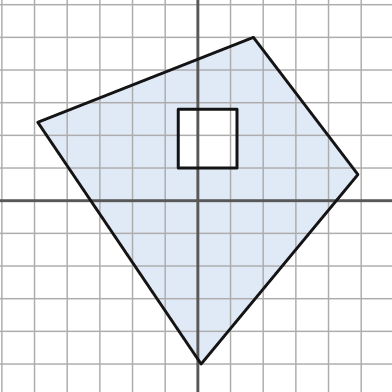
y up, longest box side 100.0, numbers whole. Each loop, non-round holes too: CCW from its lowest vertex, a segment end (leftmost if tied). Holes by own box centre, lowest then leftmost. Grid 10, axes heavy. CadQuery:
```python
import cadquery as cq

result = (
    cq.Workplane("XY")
    .moveTo(1.0, -50.0)
    .lineTo(49.0, 8.0)
    .lineTo(17.0, 50.0)
    .lineTo(-49.0, 24.0)
    .close()
    .moveTo(-6.0, 10.0)
    .lineTo(12.0, 10.0)
    .lineTo(12.0, 28.0)
    .lineTo(-6.0, 28.0)
    .close()
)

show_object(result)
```